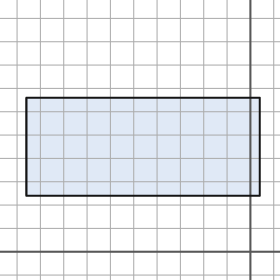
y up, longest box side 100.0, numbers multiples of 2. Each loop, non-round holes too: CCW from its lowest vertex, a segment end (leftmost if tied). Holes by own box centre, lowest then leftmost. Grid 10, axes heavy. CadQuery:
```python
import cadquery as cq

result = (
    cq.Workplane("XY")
    .moveTo(-96.0, 24.0)
    .lineTo(4.0, 24.0)
    .lineTo(4.0, 66.0)
    .lineTo(-96.0, 66.0)
    .close()
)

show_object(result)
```